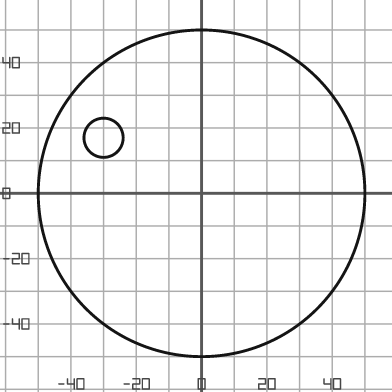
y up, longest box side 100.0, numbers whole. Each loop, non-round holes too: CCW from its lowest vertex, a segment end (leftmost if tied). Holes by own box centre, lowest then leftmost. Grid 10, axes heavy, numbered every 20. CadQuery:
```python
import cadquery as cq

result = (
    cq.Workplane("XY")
    .moveTo(0.0, 0.0)
    .circle(50.0)
    .moveTo(-30.0, 17.0)
    .circle(6.0)
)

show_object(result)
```